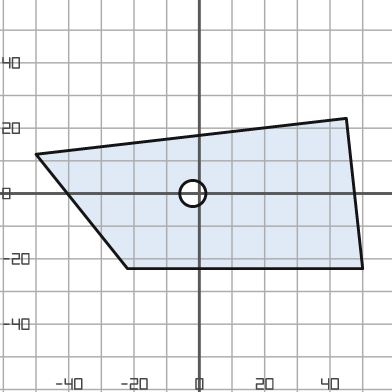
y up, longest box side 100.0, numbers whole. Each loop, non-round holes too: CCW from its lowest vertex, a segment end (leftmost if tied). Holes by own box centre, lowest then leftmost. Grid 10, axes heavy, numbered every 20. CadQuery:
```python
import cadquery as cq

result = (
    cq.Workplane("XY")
    .moveTo(-22.0, -23.0)
    .lineTo(50.0, -23.0)
    .lineTo(45.0, 23.0)
    .lineTo(-50.0, 12.0)
    .close()
    .moveTo(-2.0, 0.0)
    .circle(4.0)
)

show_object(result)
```